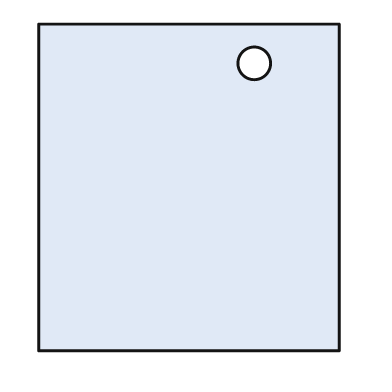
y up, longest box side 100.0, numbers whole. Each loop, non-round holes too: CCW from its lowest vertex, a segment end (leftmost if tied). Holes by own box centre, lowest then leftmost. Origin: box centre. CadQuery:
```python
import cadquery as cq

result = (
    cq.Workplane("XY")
    .moveTo(-46.0, -50.0)
    .lineTo(46.0, -50.0)
    .lineTo(46.0, 50.0)
    .lineTo(-46.0, 50.0)
    .close()
    .moveTo(20.0, 38.0)
    .circle(5.0)
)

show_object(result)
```